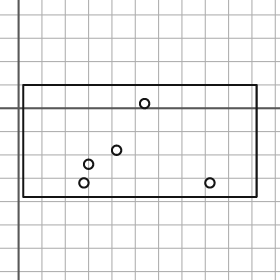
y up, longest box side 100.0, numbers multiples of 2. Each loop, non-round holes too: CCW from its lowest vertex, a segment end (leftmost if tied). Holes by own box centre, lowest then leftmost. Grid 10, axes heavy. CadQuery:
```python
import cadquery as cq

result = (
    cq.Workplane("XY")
    .moveTo(2.0, -38.0)
    .lineTo(102.0, -38.0)
    .lineTo(102.0, 10.0)
    .lineTo(2.0, 10.0)
    .close()
    .moveTo(28.0, -32.0)
    .circle(2.0)
    .moveTo(82.0, -32.0)
    .circle(2.0)
    .moveTo(30.0, -24.0)
    .circle(2.0)
    .moveTo(42.0, -18.0)
    .circle(2.0)
    .moveTo(54.0, 2.0)
    .circle(2.0)
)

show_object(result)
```